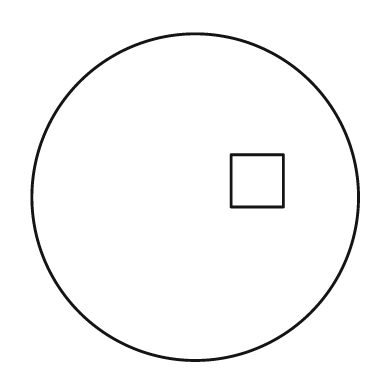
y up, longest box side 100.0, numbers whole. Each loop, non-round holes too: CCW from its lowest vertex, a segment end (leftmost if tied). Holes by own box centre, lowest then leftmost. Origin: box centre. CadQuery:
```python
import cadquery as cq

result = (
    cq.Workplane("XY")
    .moveTo(0.0, 0.0)
    .circle(50.0)
    .moveTo(11.0, -3.0)
    .lineTo(27.0, -3.0)
    .lineTo(27.0, 13.0)
    .lineTo(11.0, 13.0)
    .close()
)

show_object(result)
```